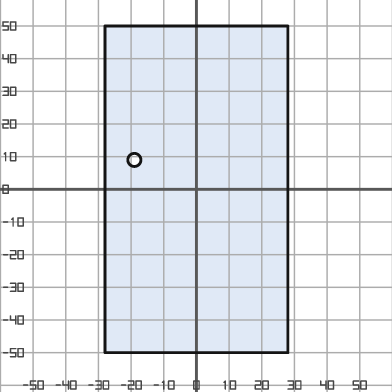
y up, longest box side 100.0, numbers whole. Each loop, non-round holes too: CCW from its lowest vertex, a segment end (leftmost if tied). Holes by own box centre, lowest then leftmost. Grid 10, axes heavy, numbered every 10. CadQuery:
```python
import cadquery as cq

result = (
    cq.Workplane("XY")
    .moveTo(-28.0, -50.0)
    .lineTo(28.0, -50.0)
    .lineTo(28.0, 50.0)
    .lineTo(-28.0, 50.0)
    .close()
    .moveTo(-19.0, 9.0)
    .circle(2.0)
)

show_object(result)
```